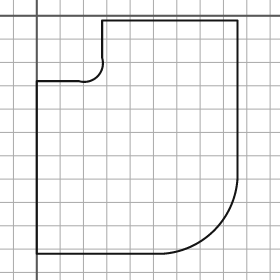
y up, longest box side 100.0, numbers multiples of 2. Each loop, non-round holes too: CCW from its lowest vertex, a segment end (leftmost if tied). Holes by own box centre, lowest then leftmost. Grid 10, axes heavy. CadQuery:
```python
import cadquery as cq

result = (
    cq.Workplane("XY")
    .moveTo(0.0, -102.0)
    .lineTo(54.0, -102.0)
    .threePointArc((76.0, -92.0), (86.0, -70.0))
    .lineTo(86.0, -2.0)
    .lineTo(28.0, -2.0)
    .lineTo(28.0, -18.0)
    .threePointArc((26.0, -26.0), (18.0, -28.0))
    .lineTo(0.0, -28.0)
    .close()
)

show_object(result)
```